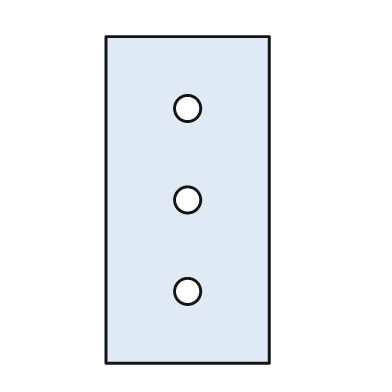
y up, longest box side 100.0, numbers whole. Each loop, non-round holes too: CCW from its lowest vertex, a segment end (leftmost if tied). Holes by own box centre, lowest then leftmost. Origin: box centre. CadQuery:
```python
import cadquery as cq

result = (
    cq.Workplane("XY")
    .moveTo(-25.0, -50.0)
    .lineTo(25.0, -50.0)
    .lineTo(25.0, 50.0)
    .lineTo(-25.0, 50.0)
    .close()
    .moveTo(0.0, -28.0)
    .circle(4.0)
    .moveTo(0.0, 0.0)
    .circle(4.0)
    .moveTo(0.0, 28.0)
    .circle(4.0)
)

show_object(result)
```